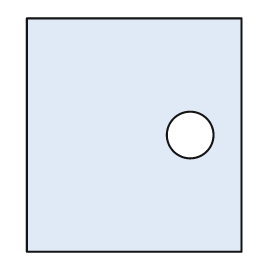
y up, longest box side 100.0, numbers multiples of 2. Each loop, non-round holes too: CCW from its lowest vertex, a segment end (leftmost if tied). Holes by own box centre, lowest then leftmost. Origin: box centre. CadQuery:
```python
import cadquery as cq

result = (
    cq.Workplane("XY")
    .moveTo(-46.0, -50.0)
    .lineTo(46.0, -50.0)
    .lineTo(46.0, 50.0)
    .lineTo(-46.0, 50.0)
    .close()
    .moveTo(24.0, 0.0)
    .circle(10.0)
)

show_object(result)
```